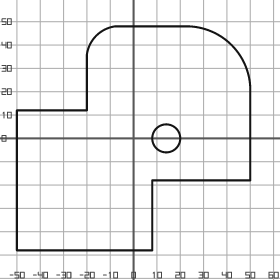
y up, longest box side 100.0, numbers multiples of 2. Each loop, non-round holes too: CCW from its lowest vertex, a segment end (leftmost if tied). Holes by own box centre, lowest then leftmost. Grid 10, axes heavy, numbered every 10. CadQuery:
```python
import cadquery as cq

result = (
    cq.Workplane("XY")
    .moveTo(-50.0, -48.0)
    .lineTo(8.0, -48.0)
    .lineTo(8.0, -18.0)
    .lineTo(50.0, -18.0)
    .lineTo(50.0, 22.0)
    .threePointArc((42.0, 40.0), (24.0, 48.0))
    .lineTo(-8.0, 48.0)
    .threePointArc((-16.0, 44.0), (-20.0, 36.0))
    .lineTo(-20.0, 12.0)
    .lineTo(-50.0, 12.0)
    .close()
    .moveTo(14.0, 0.0)
    .circle(6.0)
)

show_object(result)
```